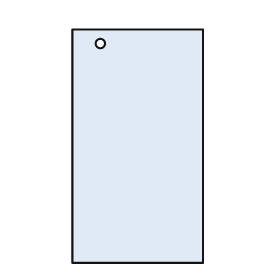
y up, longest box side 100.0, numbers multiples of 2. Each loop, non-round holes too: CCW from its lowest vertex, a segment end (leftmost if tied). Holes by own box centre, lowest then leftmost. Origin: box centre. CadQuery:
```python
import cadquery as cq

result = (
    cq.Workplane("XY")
    .moveTo(-28.0, -50.0)
    .lineTo(28.0, -50.0)
    .lineTo(28.0, 50.0)
    .lineTo(-28.0, 50.0)
    .close()
    .moveTo(-16.0, 44.0)
    .circle(2.0)
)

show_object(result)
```